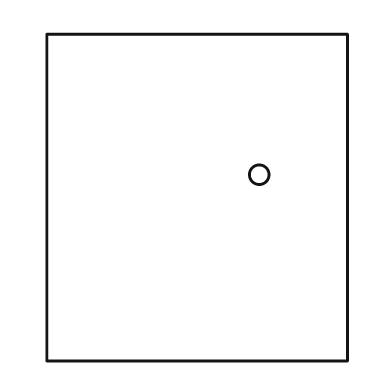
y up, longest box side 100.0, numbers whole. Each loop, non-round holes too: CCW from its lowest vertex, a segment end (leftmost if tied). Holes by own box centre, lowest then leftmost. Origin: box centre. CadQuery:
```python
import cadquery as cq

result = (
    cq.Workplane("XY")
    .moveTo(-46.0, -50.0)
    .lineTo(46.0, -50.0)
    .lineTo(46.0, 50.0)
    .lineTo(-46.0, 50.0)
    .close()
    .moveTo(19.0, 7.0)
    .circle(3.0)
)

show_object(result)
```